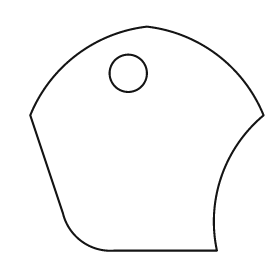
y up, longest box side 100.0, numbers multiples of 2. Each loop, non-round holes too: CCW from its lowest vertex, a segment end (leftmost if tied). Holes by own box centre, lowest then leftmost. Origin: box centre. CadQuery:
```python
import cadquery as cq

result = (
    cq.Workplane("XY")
    .moveTo(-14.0, -48.0)
    .lineTo(30.0, -48.0)
    .threePointArc((32.0, -16.0), (50.0, 10.0))
    .threePointArc((30.0, 36.0), (0.0, 48.0))
    .threePointArc((-30.0, 36.0), (-50.0, 10.0))
    .lineTo(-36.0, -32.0)
    .threePointArc((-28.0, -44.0), (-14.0, -48.0))
    .close()
    .moveTo(-8.0, 28.0)
    .circle(8.0)
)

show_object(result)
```